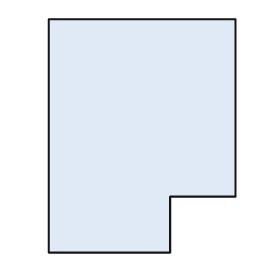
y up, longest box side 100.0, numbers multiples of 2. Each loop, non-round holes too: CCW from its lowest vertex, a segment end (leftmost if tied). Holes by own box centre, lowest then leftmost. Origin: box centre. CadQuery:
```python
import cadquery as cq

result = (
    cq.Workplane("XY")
    .moveTo(-40.0, -50.0)
    .lineTo(12.0, -50.0)
    .lineTo(12.0, -26.0)
    .lineTo(40.0, -26.0)
    .lineTo(40.0, 50.0)
    .lineTo(-40.0, 50.0)
    .close()
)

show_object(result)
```